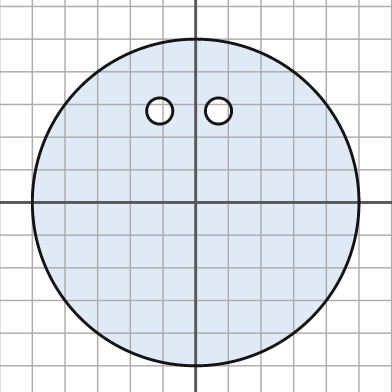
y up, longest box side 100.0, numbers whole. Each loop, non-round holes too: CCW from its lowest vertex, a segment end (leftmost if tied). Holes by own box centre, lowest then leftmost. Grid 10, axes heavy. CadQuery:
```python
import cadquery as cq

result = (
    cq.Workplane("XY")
    .moveTo(0.0, 0.0)
    .circle(50.0)
    .moveTo(-11.0, 28.0)
    .circle(4.0)
    .moveTo(7.0, 28.0)
    .circle(4.0)
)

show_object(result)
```